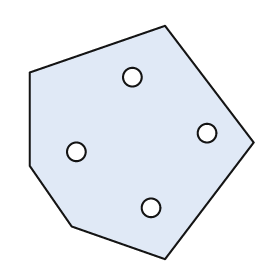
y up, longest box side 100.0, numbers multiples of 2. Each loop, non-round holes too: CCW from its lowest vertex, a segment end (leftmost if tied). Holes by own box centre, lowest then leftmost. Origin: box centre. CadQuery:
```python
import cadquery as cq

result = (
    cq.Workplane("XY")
    .moveTo(10.0, -50.0)
    .lineTo(48.0, 0.0)
    .lineTo(10.0, 50.0)
    .lineTo(-48.0, 30.0)
    .lineTo(-48.0, -10.0)
    .lineTo(-30.0, -36.0)
    .close()
    .moveTo(4.0, -28.0)
    .circle(4.0)
    .moveTo(-28.0, -4.0)
    .circle(4.0)
    .moveTo(28.0, 4.0)
    .circle(4.0)
    .moveTo(-4.0, 28.0)
    .circle(4.0)
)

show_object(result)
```